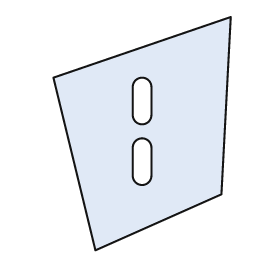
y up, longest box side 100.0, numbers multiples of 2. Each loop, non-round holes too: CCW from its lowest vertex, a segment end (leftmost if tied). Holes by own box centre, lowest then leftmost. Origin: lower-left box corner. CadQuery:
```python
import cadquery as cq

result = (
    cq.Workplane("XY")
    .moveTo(18.0, 0.0)
    .lineTo(72.0, 24.0)
    .lineTo(76.0, 100.0)
    .lineTo(0.0, 74.0)
    .close()
    .moveTo(34.0, 32.0)
    .threePointArc((38.0, 28.0), (42.0, 32.0))
    .lineTo(42.0, 44.0)
    .threePointArc((38.0, 48.0), (34.0, 44.0))
    .close()
    .moveTo(34.0, 58.0)
    .threePointArc((38.0, 54.0), (42.0, 58.0))
    .lineTo(42.0, 70.0)
    .threePointArc((38.0, 74.0), (34.0, 70.0))
    .close()
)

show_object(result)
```